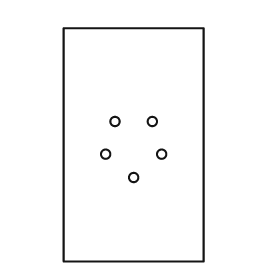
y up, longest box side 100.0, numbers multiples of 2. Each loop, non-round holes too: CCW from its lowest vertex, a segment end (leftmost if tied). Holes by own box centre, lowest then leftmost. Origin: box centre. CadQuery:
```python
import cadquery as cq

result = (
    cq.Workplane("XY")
    .moveTo(-30.0, -50.0)
    .lineTo(30.0, -50.0)
    .lineTo(30.0, 50.0)
    .lineTo(-30.0, 50.0)
    .close()
    .moveTo(0.0, -14.0)
    .circle(2.0)
    .moveTo(-12.0, -4.0)
    .circle(2.0)
    .moveTo(12.0, -4.0)
    .circle(2.0)
    .moveTo(-8.0, 10.0)
    .circle(2.0)
    .moveTo(8.0, 10.0)
    .circle(2.0)
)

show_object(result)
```